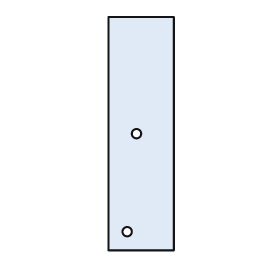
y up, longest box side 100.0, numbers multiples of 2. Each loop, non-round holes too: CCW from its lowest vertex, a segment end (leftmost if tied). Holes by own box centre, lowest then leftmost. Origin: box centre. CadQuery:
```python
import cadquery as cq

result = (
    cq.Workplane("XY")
    .moveTo(-14.0, -50.0)
    .lineTo(14.0, -50.0)
    .lineTo(14.0, 50.0)
    .lineTo(-14.0, 50.0)
    .close()
    .moveTo(-6.0, -42.0)
    .circle(2.0)
    .moveTo(-2.0, 0.0)
    .circle(2.0)
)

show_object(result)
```